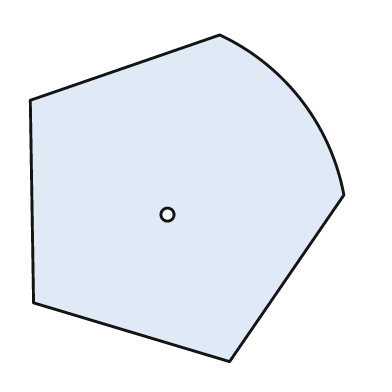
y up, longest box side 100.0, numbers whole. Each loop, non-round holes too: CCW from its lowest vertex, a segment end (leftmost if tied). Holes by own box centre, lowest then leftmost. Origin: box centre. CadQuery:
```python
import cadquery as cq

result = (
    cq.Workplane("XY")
    .moveTo(13.0, -50.0)
    .lineTo(48.0, 1.0)
    .threePointArc((35.0, 30.0), (10.0, 50.0))
    .lineTo(-48.0, 30.0)
    .lineTo(-47.0, -32.0)
    .close()
    .moveTo(-6.0, -5.0)
    .circle(2.0)
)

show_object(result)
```